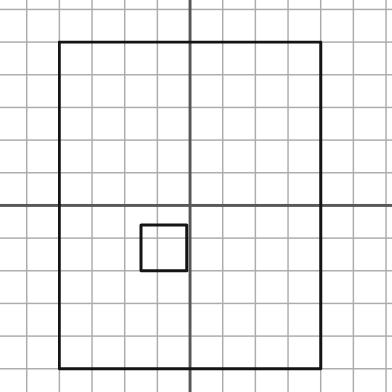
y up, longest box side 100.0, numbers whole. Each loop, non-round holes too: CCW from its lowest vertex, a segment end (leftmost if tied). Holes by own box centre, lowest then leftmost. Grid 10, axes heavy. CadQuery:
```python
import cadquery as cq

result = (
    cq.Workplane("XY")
    .moveTo(-40.0, -50.0)
    .lineTo(40.0, -50.0)
    .lineTo(40.0, 50.0)
    .lineTo(-40.0, 50.0)
    .close()
    .moveTo(-15.0, -20.0)
    .lineTo(-1.0, -20.0)
    .lineTo(-1.0, -6.0)
    .lineTo(-15.0, -6.0)
    .close()
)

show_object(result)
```